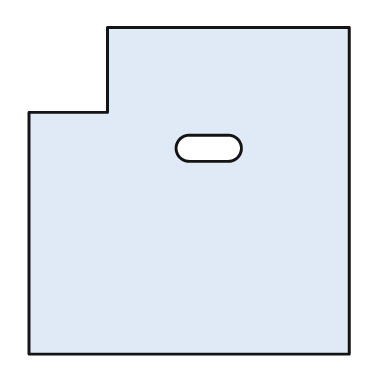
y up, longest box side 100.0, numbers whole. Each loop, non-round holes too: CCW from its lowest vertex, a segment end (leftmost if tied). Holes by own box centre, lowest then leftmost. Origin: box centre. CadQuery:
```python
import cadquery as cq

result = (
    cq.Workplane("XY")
    .moveTo(-49.0, -50.0)
    .lineTo(49.0, -50.0)
    .lineTo(49.0, 50.0)
    .lineTo(-25.0, 50.0)
    .lineTo(-25.0, 24.0)
    .lineTo(-49.0, 24.0)
    .close()
    .moveTo(0.0, 9.0)
    .lineTo(12.0, 9.0)
    .threePointArc((16.0, 13.0), (12.0, 17.0))
    .lineTo(0.0, 17.0)
    .threePointArc((-4.0, 13.0), (0.0, 9.0))
    .close()
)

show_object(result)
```